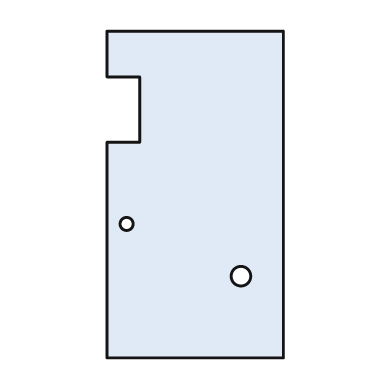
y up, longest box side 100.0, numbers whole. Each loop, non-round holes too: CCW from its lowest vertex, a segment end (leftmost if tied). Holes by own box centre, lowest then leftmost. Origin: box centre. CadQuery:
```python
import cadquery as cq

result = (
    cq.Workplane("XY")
    .moveTo(-27.0, -50.0)
    .lineTo(27.0, -50.0)
    .lineTo(27.0, 50.0)
    .lineTo(-27.0, 50.0)
    .lineTo(-27.0, 36.0)
    .lineTo(-17.0, 36.0)
    .lineTo(-17.0, 16.0)
    .lineTo(-27.0, 16.0)
    .close()
    .moveTo(14.0, -25.0)
    .circle(3.0)
    .moveTo(-21.0, -9.0)
    .circle(2.0)
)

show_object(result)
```